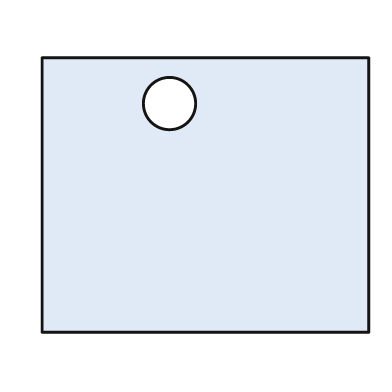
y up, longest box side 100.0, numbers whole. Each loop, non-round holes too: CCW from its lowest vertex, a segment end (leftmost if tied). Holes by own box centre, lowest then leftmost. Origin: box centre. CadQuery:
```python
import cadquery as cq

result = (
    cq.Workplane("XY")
    .moveTo(-50.0, -42.0)
    .lineTo(50.0, -42.0)
    .lineTo(50.0, 42.0)
    .lineTo(-50.0, 42.0)
    .close()
    .moveTo(-11.0, 28.0)
    .circle(8.0)
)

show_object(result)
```